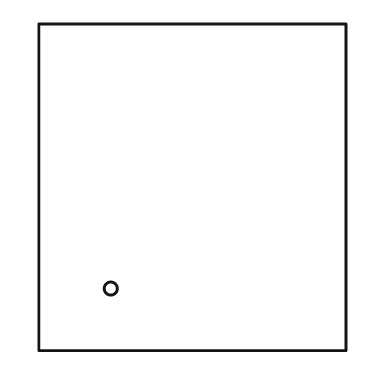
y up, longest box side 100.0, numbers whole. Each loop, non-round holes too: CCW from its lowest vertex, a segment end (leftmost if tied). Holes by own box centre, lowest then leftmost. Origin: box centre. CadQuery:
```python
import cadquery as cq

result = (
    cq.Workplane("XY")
    .moveTo(-47.0, -50.0)
    .lineTo(47.0, -50.0)
    .lineTo(47.0, 50.0)
    .lineTo(-47.0, 50.0)
    .close()
    .moveTo(-25.0, -31.0)
    .circle(2.0)
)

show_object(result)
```